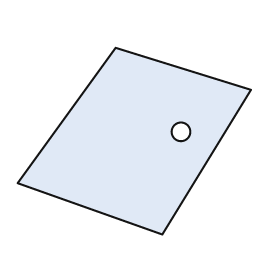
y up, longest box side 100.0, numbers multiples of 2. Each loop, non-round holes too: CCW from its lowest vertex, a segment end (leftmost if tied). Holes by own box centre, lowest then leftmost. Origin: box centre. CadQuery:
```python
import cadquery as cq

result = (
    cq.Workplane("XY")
    .moveTo(12.0, -40.0)
    .lineTo(50.0, 22.0)
    .lineTo(-8.0, 40.0)
    .lineTo(-50.0, -18.0)
    .close()
    .moveTo(20.0, 4.0)
    .circle(4.0)
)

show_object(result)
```